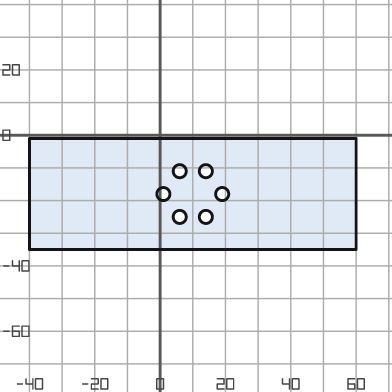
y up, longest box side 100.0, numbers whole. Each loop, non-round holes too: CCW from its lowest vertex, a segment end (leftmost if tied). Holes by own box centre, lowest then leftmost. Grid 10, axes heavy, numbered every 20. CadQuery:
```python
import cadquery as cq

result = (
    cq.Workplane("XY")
    .moveTo(-40.0, -35.0)
    .lineTo(60.0, -35.0)
    .lineTo(60.0, -1.0)
    .lineTo(-40.0, -1.0)
    .close()
    .moveTo(6.0, -25.0)
    .circle(2.0)
    .moveTo(14.0, -25.0)
    .circle(2.0)
    .moveTo(1.0, -18.0)
    .circle(2.0)
    .moveTo(19.0, -18.0)
    .circle(2.0)
    .moveTo(6.0, -11.0)
    .circle(2.0)
    .moveTo(14.0, -11.0)
    .circle(2.0)
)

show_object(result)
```